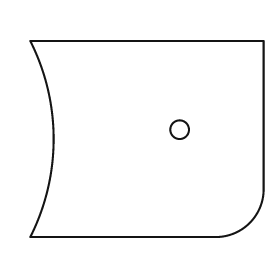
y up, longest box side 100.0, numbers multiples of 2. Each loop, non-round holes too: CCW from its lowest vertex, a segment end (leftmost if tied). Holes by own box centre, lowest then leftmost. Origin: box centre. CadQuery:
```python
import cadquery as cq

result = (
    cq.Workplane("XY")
    .moveTo(-50.0, -42.0)
    .lineTo(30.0, -42.0)
    .threePointArc((44.0, -36.0), (50.0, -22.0))
    .lineTo(50.0, 42.0)
    .lineTo(-50.0, 42.0)
    .threePointArc((-40.0, 0.0), (-50.0, -42.0))
    .close()
    .moveTo(14.0, 4.0)
    .circle(4.0)
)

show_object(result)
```